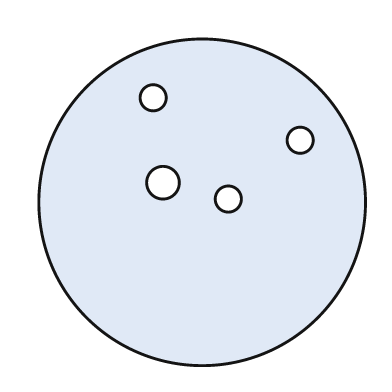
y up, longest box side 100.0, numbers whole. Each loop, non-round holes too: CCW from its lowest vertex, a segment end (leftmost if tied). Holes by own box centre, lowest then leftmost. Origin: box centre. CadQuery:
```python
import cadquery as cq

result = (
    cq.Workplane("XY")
    .moveTo(0.0, 0.0)
    .circle(50.0)
    .moveTo(8.0, 1.0)
    .circle(4.0)
    .moveTo(-12.0, 6.0)
    .circle(5.0)
    .moveTo(30.0, 19.0)
    .circle(4.0)
    .moveTo(-15.0, 32.0)
    .circle(4.0)
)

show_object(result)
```